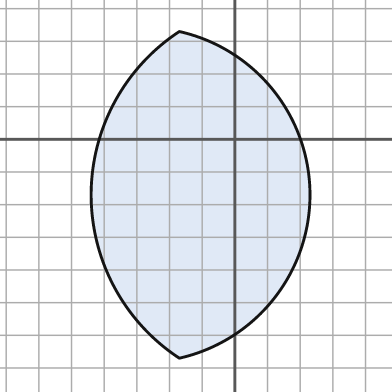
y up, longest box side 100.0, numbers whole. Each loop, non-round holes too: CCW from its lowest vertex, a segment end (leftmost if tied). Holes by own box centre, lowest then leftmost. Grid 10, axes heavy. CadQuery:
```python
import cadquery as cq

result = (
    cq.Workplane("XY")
    .moveTo(-17.0, -67.0)
    .threePointArc((23.0, -17.0), (-17.0, 33.0))
    .threePointArc((-44.0, -17.0), (-17.0, -67.0))
    .close()
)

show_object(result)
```